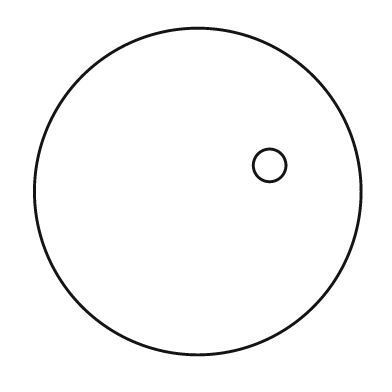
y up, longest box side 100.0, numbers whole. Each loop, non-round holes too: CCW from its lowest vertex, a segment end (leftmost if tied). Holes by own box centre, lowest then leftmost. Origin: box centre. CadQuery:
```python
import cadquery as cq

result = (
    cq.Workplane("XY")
    .moveTo(0.0, 0.0)
    .circle(50.0)
    .moveTo(22.0, 8.0)
    .circle(5.0)
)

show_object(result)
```